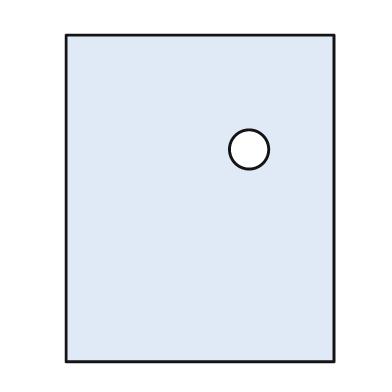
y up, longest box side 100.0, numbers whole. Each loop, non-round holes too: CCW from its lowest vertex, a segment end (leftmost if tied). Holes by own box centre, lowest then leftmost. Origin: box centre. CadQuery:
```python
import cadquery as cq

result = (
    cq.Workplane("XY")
    .moveTo(-41.0, -50.0)
    .lineTo(41.0, -50.0)
    .lineTo(41.0, 50.0)
    .lineTo(-41.0, 50.0)
    .close()
    .moveTo(15.0, 15.0)
    .circle(6.0)
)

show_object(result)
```